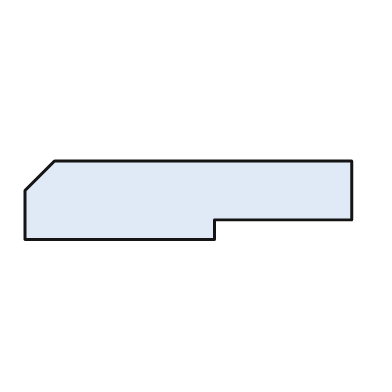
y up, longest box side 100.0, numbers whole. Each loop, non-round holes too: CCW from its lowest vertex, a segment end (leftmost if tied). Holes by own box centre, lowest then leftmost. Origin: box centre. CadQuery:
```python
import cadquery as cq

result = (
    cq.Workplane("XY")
    .moveTo(-50.0, -12.0)
    .lineTo(8.0, -12.0)
    .lineTo(8.0, -6.0)
    .lineTo(50.0, -6.0)
    .lineTo(50.0, 12.0)
    .lineTo(-41.0, 12.0)
    .lineTo(-50.0, 3.0)
    .close()
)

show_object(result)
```